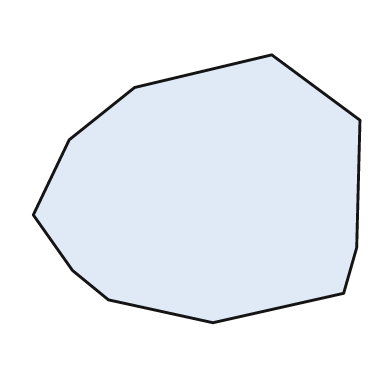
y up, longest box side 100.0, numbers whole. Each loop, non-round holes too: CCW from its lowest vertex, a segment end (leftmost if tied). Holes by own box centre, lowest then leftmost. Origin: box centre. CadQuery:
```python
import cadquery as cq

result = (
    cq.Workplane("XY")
    .moveTo(5.0, -41.0)
    .lineTo(45.0, -32.0)
    .lineTo(49.0, -18.0)
    .lineTo(50.0, 21.0)
    .lineTo(23.0, 41.0)
    .lineTo(-19.0, 31.0)
    .lineTo(-39.0, 15.0)
    .lineTo(-50.0, -8.0)
    .lineTo(-38.0, -25.0)
    .lineTo(-27.0, -34.0)
    .close()
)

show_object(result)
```